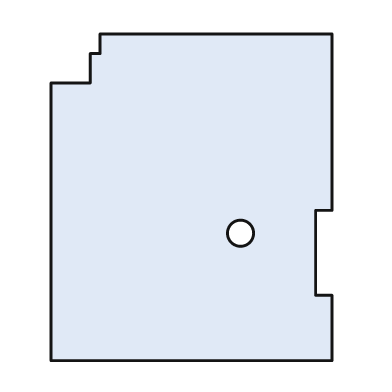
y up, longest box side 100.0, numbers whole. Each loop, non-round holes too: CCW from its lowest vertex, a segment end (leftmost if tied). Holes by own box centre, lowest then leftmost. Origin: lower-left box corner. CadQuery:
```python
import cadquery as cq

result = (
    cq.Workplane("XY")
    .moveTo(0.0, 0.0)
    .lineTo(86.0, 0.0)
    .lineTo(86.0, 20.0)
    .lineTo(81.0, 20.0)
    .lineTo(81.0, 46.0)
    .lineTo(86.0, 46.0)
    .lineTo(86.0, 100.0)
    .lineTo(15.0, 100.0)
    .lineTo(15.0, 94.0)
    .lineTo(12.0, 94.0)
    .lineTo(12.0, 85.0)
    .lineTo(0.0, 85.0)
    .close()
    .moveTo(58.0, 39.0)
    .circle(4.0)
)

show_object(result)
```